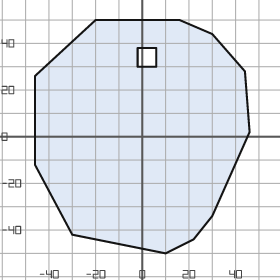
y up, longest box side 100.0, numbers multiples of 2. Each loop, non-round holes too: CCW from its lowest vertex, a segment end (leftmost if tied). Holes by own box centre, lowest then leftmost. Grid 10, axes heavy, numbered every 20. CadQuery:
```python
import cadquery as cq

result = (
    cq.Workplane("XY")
    .moveTo(10.0, -50.0)
    .lineTo(22.0, -44.0)
    .lineTo(30.0, -34.0)
    .lineTo(46.0, 2.0)
    .lineTo(44.0, 28.0)
    .lineTo(30.0, 44.0)
    .lineTo(16.0, 50.0)
    .lineTo(-20.0, 50.0)
    .lineTo(-46.0, 26.0)
    .lineTo(-46.0, -12.0)
    .lineTo(-30.0, -42.0)
    .close()
    .moveTo(-2.0, 30.0)
    .lineTo(6.0, 30.0)
    .lineTo(6.0, 38.0)
    .lineTo(-2.0, 38.0)
    .close()
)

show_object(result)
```